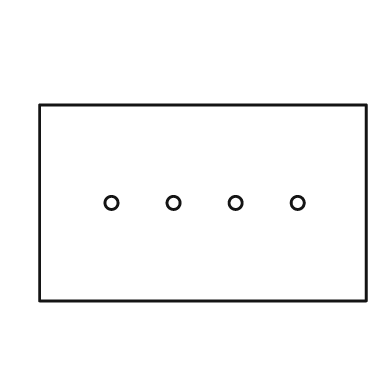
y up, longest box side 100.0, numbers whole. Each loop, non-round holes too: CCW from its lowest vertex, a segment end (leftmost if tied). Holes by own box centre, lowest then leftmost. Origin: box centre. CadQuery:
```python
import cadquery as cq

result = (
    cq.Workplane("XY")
    .moveTo(-50.0, -30.0)
    .lineTo(50.0, -30.0)
    .lineTo(50.0, 30.0)
    .lineTo(-50.0, 30.0)
    .close()
    .moveTo(-28.0, 0.0)
    .circle(2.0)
    .moveTo(-9.0, 0.0)
    .circle(2.0)
    .moveTo(10.0, 0.0)
    .circle(2.0)
    .moveTo(29.0, 0.0)
    .circle(2.0)
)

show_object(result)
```